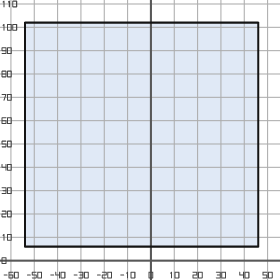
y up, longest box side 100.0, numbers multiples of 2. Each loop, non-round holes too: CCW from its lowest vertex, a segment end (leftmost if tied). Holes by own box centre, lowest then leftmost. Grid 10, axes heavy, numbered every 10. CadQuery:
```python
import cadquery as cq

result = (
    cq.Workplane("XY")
    .moveTo(-54.0, 6.0)
    .lineTo(46.0, 6.0)
    .lineTo(46.0, 102.0)
    .lineTo(-54.0, 102.0)
    .close()
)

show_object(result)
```